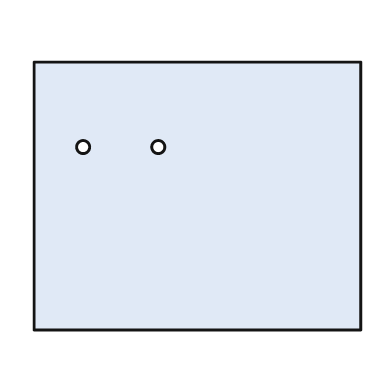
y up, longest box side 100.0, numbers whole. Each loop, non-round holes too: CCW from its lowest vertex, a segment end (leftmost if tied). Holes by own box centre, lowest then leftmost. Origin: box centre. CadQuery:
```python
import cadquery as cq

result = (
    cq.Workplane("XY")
    .moveTo(-50.0, -41.0)
    .lineTo(50.0, -41.0)
    .lineTo(50.0, 41.0)
    .lineTo(-50.0, 41.0)
    .close()
    .moveTo(-35.0, 15.0)
    .circle(2.0)
    .moveTo(-12.0, 15.0)
    .circle(2.0)
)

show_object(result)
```